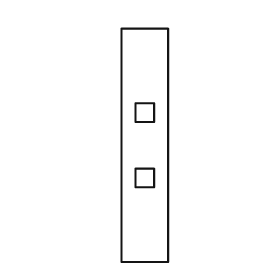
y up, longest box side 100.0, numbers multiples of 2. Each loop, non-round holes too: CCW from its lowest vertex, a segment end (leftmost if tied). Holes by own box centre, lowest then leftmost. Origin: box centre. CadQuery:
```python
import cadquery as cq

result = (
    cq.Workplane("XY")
    .moveTo(-10.0, -50.0)
    .lineTo(10.0, -50.0)
    .lineTo(10.0, 50.0)
    .lineTo(-10.0, 50.0)
    .close()
    .moveTo(-4.0, -18.0)
    .lineTo(4.0, -18.0)
    .lineTo(4.0, -10.0)
    .lineTo(-4.0, -10.0)
    .close()
    .moveTo(-4.0, 10.0)
    .lineTo(4.0, 10.0)
    .lineTo(4.0, 18.0)
    .lineTo(-4.0, 18.0)
    .close()
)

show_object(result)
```